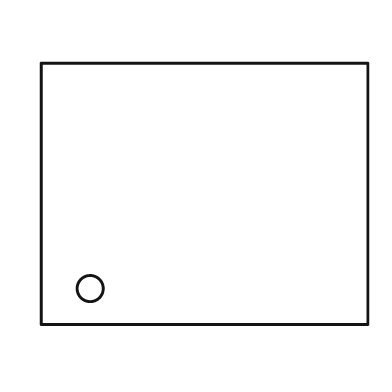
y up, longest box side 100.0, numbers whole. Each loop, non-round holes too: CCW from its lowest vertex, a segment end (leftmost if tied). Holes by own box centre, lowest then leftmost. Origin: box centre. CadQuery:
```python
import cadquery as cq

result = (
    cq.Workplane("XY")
    .moveTo(-50.0, -40.0)
    .lineTo(50.0, -40.0)
    .lineTo(50.0, 40.0)
    .lineTo(-50.0, 40.0)
    .close()
    .moveTo(-35.0, -29.0)
    .circle(4.0)
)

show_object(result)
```